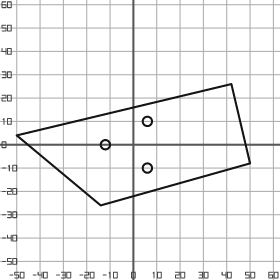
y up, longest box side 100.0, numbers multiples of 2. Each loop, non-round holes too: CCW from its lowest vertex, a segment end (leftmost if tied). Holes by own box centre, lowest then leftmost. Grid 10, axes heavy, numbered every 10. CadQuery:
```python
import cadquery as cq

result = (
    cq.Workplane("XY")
    .moveTo(-14.0, -26.0)
    .lineTo(50.0, -8.0)
    .lineTo(42.0, 26.0)
    .lineTo(-50.0, 4.0)
    .close()
    .moveTo(6.0, -10.0)
    .circle(2.0)
    .moveTo(-12.0, 0.0)
    .circle(2.0)
    .moveTo(6.0, 10.0)
    .circle(2.0)
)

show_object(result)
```